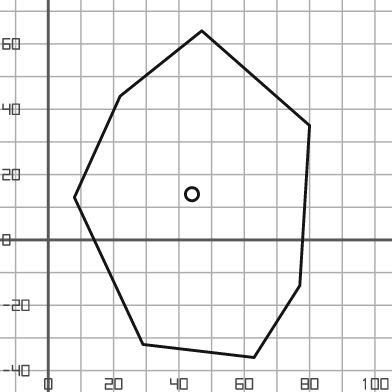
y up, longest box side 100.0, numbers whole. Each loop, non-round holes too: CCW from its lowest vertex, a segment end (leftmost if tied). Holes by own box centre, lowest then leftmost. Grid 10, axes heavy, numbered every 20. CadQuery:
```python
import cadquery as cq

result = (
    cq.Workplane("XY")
    .moveTo(63.0, -36.0)
    .lineTo(77.0, -14.0)
    .lineTo(80.0, 35.0)
    .lineTo(47.0, 64.0)
    .lineTo(22.0, 44.0)
    .lineTo(8.0, 13.0)
    .lineTo(29.0, -32.0)
    .close()
    .moveTo(44.0, 14.0)
    .circle(2.0)
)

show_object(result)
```